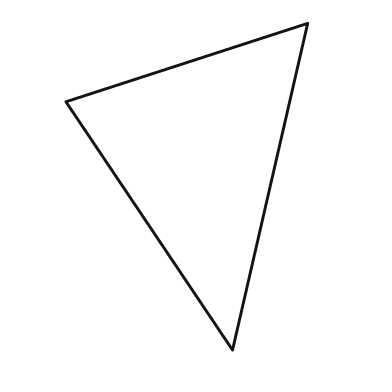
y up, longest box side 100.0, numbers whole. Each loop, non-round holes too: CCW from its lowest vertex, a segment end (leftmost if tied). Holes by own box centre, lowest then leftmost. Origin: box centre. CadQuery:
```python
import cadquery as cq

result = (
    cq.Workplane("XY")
    .moveTo(14.0, -50.0)
    .lineTo(37.0, 50.0)
    .lineTo(-37.0, 26.0)
    .close()
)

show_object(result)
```